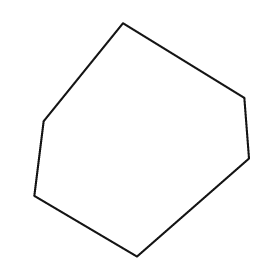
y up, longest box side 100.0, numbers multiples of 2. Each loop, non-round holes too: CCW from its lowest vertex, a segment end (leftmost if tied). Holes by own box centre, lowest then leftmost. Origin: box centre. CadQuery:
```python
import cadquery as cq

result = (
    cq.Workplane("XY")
    .moveTo(-2.0, -50.0)
    .lineTo(46.0, -8.0)
    .lineTo(44.0, 18.0)
    .lineTo(-8.0, 50.0)
    .lineTo(-42.0, 8.0)
    .lineTo(-46.0, -24.0)
    .close()
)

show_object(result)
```